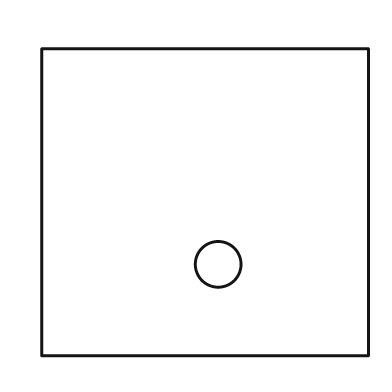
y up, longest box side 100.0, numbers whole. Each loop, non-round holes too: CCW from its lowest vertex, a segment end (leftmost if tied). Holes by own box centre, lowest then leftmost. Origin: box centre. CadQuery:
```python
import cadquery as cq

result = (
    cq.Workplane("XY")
    .moveTo(-50.0, -47.0)
    .lineTo(50.0, -47.0)
    .lineTo(50.0, 47.0)
    .lineTo(-50.0, 47.0)
    .close()
    .moveTo(4.0, -19.0)
    .circle(7.0)
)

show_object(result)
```